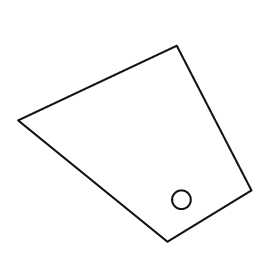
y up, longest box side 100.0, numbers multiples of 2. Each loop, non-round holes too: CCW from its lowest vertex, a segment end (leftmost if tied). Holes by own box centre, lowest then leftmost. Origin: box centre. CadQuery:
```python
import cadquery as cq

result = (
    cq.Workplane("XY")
    .moveTo(14.0, -42.0)
    .lineTo(50.0, -20.0)
    .lineTo(18.0, 42.0)
    .lineTo(-50.0, 10.0)
    .close()
    .moveTo(20.0, -24.0)
    .circle(4.0)
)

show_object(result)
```